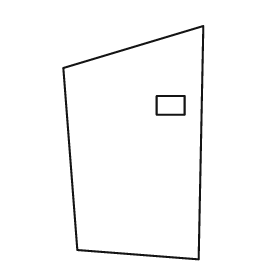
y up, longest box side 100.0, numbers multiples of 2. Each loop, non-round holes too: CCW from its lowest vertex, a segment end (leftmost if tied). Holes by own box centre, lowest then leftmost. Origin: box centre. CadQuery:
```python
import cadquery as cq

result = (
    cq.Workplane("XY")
    .moveTo(28.0, -50.0)
    .lineTo(30.0, 50.0)
    .lineTo(-30.0, 32.0)
    .lineTo(-24.0, -46.0)
    .close()
    .moveTo(10.0, 12.0)
    .lineTo(22.0, 12.0)
    .lineTo(22.0, 20.0)
    .lineTo(10.0, 20.0)
    .close()
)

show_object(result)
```